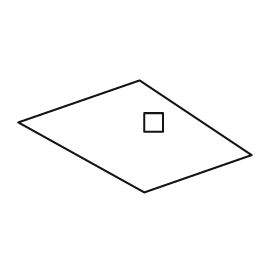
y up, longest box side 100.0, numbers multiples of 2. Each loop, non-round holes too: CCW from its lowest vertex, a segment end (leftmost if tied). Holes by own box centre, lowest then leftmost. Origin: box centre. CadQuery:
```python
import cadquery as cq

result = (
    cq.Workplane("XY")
    .moveTo(4.0, -24.0)
    .lineTo(50.0, -8.0)
    .lineTo(2.0, 24.0)
    .lineTo(-50.0, 6.0)
    .close()
    .moveTo(4.0, 2.0)
    .lineTo(12.0, 2.0)
    .lineTo(12.0, 10.0)
    .lineTo(4.0, 10.0)
    .close()
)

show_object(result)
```